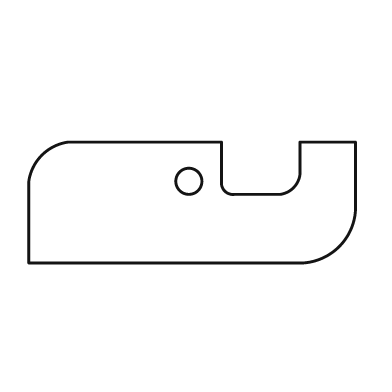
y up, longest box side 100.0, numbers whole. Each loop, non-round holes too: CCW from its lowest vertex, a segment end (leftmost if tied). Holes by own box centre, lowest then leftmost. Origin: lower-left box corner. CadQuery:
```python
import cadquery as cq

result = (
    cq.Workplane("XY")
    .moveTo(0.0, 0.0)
    .lineTo(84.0, 0.0)
    .threePointArc((95.0, 5.0), (100.0, 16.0))
    .lineTo(100.0, 37.0)
    .lineTo(83.0, 37.0)
    .lineTo(83.0, 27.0)
    .threePointArc((81.0, 23.0), (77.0, 21.0))
    .lineTo(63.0, 21.0)
    .threePointArc((60.0, 22.0), (59.0, 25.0))
    .lineTo(59.0, 37.0)
    .lineTo(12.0, 37.0)
    .threePointArc((4.0, 33.0), (0.0, 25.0))
    .close()
    .moveTo(49.0, 25.0)
    .circle(4.0)
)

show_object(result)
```